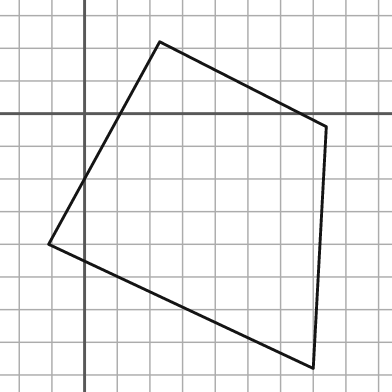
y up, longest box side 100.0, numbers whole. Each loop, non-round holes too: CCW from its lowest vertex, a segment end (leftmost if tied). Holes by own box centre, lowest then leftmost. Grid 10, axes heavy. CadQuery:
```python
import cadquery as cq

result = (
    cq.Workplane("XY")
    .moveTo(70.0, -78.0)
    .lineTo(74.0, -4.0)
    .lineTo(23.0, 22.0)
    .lineTo(-11.0, -40.0)
    .close()
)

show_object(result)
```